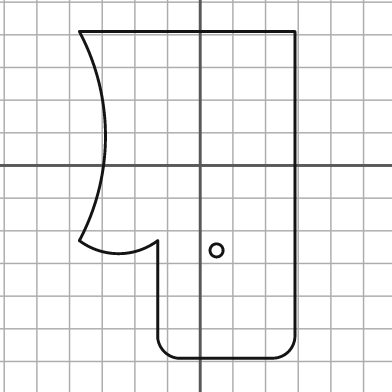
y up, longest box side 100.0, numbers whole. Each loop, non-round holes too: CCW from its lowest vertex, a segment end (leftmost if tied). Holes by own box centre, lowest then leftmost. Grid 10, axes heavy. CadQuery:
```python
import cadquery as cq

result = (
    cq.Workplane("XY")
    .moveTo(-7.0, -59.0)
    .lineTo(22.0, -59.0)
    .threePointArc((27.0, -57.0), (29.0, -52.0))
    .lineTo(29.0, 41.0)
    .lineTo(-37.0, 41.0)
    .threePointArc((-29.0, 9.0), (-37.0, -23.0))
    .threePointArc((-25.0, -27.0), (-13.0, -23.0))
    .lineTo(-13.0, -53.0)
    .threePointArc((-11.0, -57.0), (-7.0, -59.0))
    .close()
    .moveTo(5.0, -26.0)
    .circle(2.0)
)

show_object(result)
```